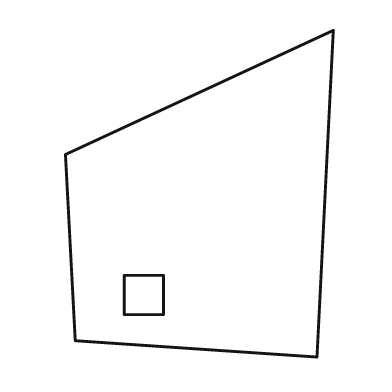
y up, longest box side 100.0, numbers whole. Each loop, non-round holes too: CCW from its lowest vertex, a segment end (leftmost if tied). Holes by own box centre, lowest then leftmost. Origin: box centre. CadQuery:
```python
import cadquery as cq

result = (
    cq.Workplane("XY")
    .moveTo(36.0, -50.0)
    .lineTo(41.0, 50.0)
    .lineTo(-41.0, 12.0)
    .lineTo(-38.0, -45.0)
    .close()
    .moveTo(-23.0, -37.0)
    .lineTo(-11.0, -37.0)
    .lineTo(-11.0, -25.0)
    .lineTo(-23.0, -25.0)
    .close()
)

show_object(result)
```